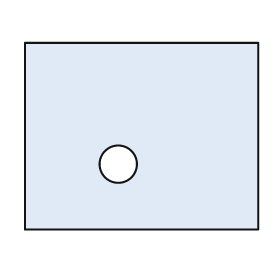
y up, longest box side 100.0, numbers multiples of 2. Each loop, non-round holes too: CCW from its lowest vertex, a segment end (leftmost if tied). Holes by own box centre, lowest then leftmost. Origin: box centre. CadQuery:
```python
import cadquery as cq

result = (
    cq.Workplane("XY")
    .moveTo(-50.0, -40.0)
    .lineTo(50.0, -40.0)
    .lineTo(50.0, 40.0)
    .lineTo(-50.0, 40.0)
    .close()
    .moveTo(-10.0, -12.0)
    .circle(8.0)
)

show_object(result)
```